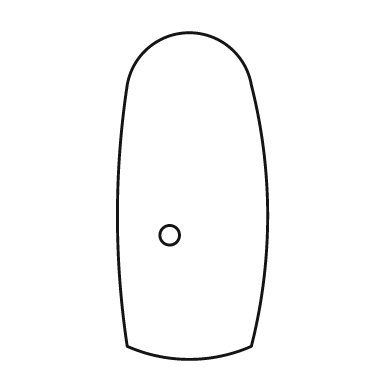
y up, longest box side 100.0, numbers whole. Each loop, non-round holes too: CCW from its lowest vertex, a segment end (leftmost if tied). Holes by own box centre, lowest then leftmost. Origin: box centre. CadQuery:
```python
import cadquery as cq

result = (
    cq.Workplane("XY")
    .moveTo(-20.0, -46.0)
    .threePointArc((-1.0, -50.0), (18.0, -46.0))
    .threePointArc((23.0, -6.0), (18.0, 34.0))
    .threePointArc((-1.0, 50.0), (-20.0, 34.0))
    .threePointArc((-23.0, -6.0), (-20.0, -46.0))
    .close()
    .moveTo(-7.0, -12.0)
    .circle(3.0)
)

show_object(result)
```